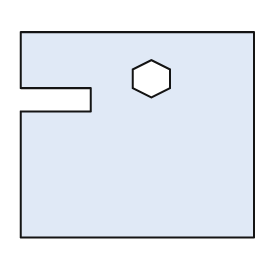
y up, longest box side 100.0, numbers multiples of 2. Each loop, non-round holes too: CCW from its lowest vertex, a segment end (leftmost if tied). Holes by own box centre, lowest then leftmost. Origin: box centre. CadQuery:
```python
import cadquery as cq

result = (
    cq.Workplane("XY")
    .moveTo(-50.0, -44.0)
    .lineTo(50.0, -44.0)
    .lineTo(50.0, 44.0)
    .lineTo(-50.0, 44.0)
    .lineTo(-50.0, 20.0)
    .lineTo(-20.0, 20.0)
    .lineTo(-20.0, 10.0)
    .lineTo(-50.0, 10.0)
    .close()
    .moveTo(6.0, 16.0)
    .lineTo(14.0, 20.0)
    .lineTo(14.0, 28.0)
    .lineTo(6.0, 32.0)
    .lineTo(-2.0, 28.0)
    .lineTo(-2.0, 20.0)
    .close()
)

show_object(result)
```